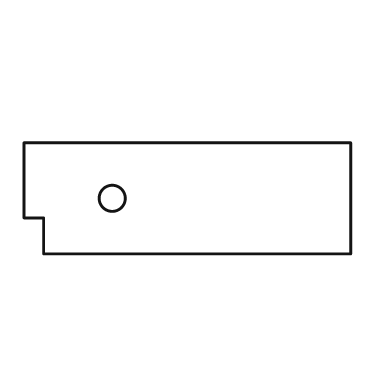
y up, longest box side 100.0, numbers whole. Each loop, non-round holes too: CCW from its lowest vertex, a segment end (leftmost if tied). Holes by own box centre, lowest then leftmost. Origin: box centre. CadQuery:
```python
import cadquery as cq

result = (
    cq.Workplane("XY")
    .moveTo(-44.0, -17.0)
    .lineTo(50.0, -17.0)
    .lineTo(50.0, 17.0)
    .lineTo(-50.0, 17.0)
    .lineTo(-50.0, -6.0)
    .lineTo(-44.0, -6.0)
    .close()
    .moveTo(-23.0, 0.0)
    .circle(4.0)
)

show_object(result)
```